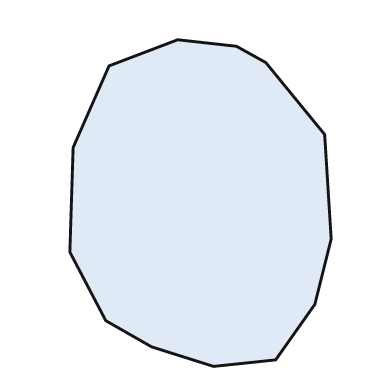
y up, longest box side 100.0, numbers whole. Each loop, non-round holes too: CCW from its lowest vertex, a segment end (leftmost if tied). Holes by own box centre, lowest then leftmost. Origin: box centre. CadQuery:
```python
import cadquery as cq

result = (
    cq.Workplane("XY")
    .moveTo(4.0, -50.0)
    .lineTo(23.0, -48.0)
    .lineTo(35.0, -31.0)
    .lineTo(40.0, -11.0)
    .lineTo(38.0, 21.0)
    .lineTo(20.0, 43.0)
    .lineTo(11.0, 48.0)
    .lineTo(-7.0, 50.0)
    .lineTo(-28.0, 42.0)
    .lineTo(-39.0, 17.0)
    .lineTo(-40.0, -15.0)
    .lineTo(-29.0, -36.0)
    .lineTo(-15.0, -44.0)
    .close()
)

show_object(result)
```